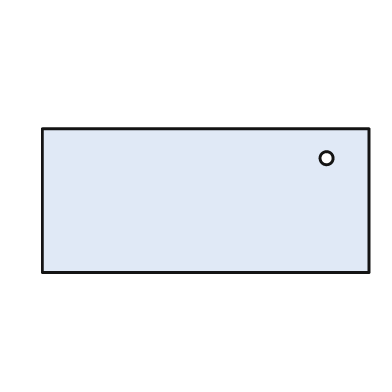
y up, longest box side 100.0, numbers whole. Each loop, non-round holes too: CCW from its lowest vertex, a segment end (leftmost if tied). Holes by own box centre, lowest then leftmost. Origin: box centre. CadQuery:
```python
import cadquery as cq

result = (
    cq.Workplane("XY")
    .moveTo(-50.0, -22.0)
    .lineTo(50.0, -22.0)
    .lineTo(50.0, 22.0)
    .lineTo(-50.0, 22.0)
    .close()
    .moveTo(37.0, 13.0)
    .circle(2.0)
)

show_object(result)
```